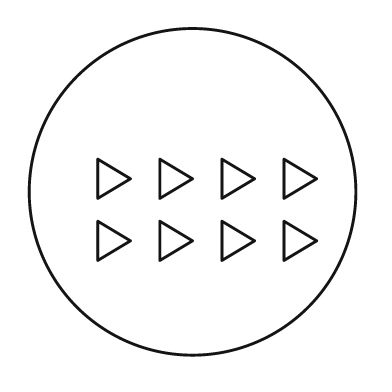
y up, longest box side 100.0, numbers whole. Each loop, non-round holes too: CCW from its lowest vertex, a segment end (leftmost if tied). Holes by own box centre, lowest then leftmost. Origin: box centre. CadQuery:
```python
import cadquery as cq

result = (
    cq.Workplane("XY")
    .moveTo(0.0, 0.0)
    .circle(50.0)
    .moveTo(-29.0, -21.0)
    .lineTo(-19.0, -15.0)
    .lineTo(-29.0, -9.0)
    .close()
    .moveTo(-10.0, -21.0)
    .lineTo(0.0, -15.0)
    .lineTo(-10.0, -9.0)
    .close()
    .moveTo(9.0, -21.0)
    .lineTo(19.0, -15.0)
    .lineTo(9.0, -9.0)
    .close()
    .moveTo(28.0, -21.0)
    .lineTo(38.0, -15.0)
    .lineTo(28.0, -9.0)
    .close()
    .moveTo(-29.0, -2.0)
    .lineTo(-19.0, 4.0)
    .lineTo(-29.0, 10.0)
    .close()
    .moveTo(-10.0, -2.0)
    .lineTo(0.0, 4.0)
    .lineTo(-10.0, 10.0)
    .close()
    .moveTo(9.0, -2.0)
    .lineTo(19.0, 4.0)
    .lineTo(9.0, 10.0)
    .close()
    .moveTo(28.0, -2.0)
    .lineTo(38.0, 4.0)
    .lineTo(28.0, 10.0)
    .close()
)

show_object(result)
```